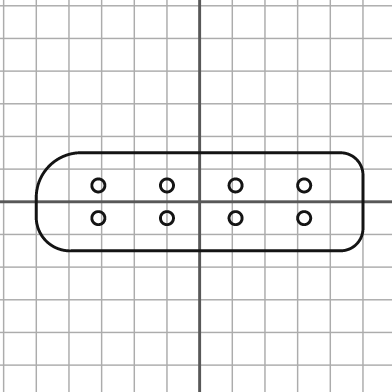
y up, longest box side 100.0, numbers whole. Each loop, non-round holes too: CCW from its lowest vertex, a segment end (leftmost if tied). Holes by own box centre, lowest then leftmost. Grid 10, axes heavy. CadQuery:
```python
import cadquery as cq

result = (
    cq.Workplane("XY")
    .moveTo(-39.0, -15.0)
    .lineTo(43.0, -15.0)
    .threePointArc((48.0, -13.0), (50.0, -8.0))
    .lineTo(50.0, 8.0)
    .threePointArc((48.0, 13.0), (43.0, 15.0))
    .lineTo(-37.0, 15.0)
    .threePointArc((-46.0, 11.0), (-50.0, 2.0))
    .lineTo(-50.0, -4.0)
    .threePointArc((-47.0, -12.0), (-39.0, -15.0))
    .close()
    .moveTo(-31.0, -5.0)
    .circle(2.0)
    .moveTo(-10.0, -5.0)
    .circle(2.0)
    .moveTo(11.0, -5.0)
    .circle(2.0)
    .moveTo(32.0, -5.0)
    .circle(2.0)
    .moveTo(-31.0, 5.0)
    .circle(2.0)
    .moveTo(-10.0, 5.0)
    .circle(2.0)
    .moveTo(11.0, 5.0)
    .circle(2.0)
    .moveTo(32.0, 5.0)
    .circle(2.0)
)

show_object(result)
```